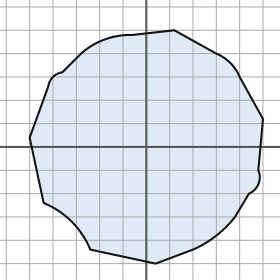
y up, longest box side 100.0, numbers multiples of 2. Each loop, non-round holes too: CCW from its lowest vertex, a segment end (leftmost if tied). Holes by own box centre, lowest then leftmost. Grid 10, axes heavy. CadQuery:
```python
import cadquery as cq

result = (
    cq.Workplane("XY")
    .moveTo(4.0, -50.0)
    .lineTo(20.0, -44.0)
    .threePointArc((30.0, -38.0), (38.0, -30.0))
    .lineTo(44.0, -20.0)
    .threePointArc((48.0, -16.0), (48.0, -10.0))
    .lineTo(50.0, 12.0)
    .lineTo(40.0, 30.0)
    .threePointArc((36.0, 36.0), (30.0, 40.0))
    .lineTo(12.0, 50.0)
    .lineTo(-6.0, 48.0)
    .threePointArc((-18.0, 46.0), (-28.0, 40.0))
    .lineTo(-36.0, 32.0)
    .threePointArc((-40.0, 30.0), (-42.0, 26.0))
    .lineTo(-50.0, 4.0)
    .lineTo(-44.0, -24.0)
    .threePointArc((-32.0, -32.0), (-24.0, -44.0))
    .close()
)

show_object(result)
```